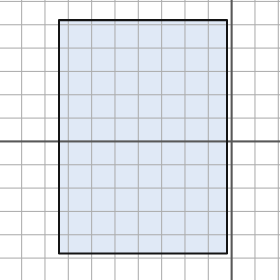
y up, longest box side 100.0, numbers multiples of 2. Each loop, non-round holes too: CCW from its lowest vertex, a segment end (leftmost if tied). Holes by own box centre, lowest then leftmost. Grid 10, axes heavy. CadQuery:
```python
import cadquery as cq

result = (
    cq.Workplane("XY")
    .moveTo(-74.0, -48.0)
    .lineTo(-2.0, -48.0)
    .lineTo(-2.0, 52.0)
    .lineTo(-74.0, 52.0)
    .close()
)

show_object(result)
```